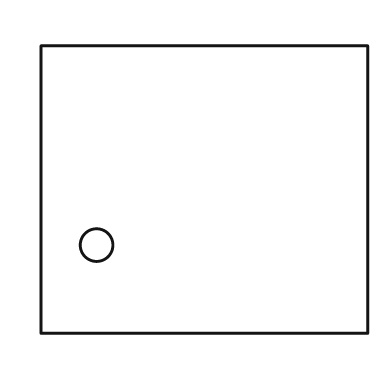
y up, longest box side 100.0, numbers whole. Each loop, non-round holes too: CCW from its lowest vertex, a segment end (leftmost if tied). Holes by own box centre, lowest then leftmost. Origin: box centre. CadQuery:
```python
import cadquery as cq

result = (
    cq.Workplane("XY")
    .moveTo(-50.0, -44.0)
    .lineTo(50.0, -44.0)
    .lineTo(50.0, 44.0)
    .lineTo(-50.0, 44.0)
    .close()
    .moveTo(-33.0, -17.0)
    .circle(5.0)
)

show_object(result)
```